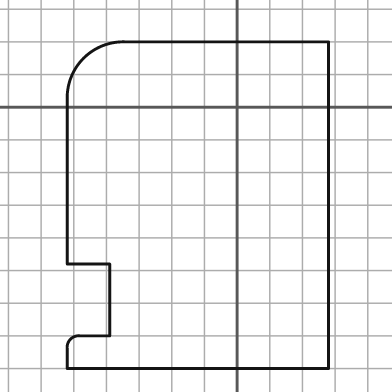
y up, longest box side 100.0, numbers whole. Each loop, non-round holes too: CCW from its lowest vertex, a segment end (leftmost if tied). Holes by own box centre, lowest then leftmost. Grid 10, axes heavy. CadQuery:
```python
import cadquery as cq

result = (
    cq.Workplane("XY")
    .moveTo(-52.0, -80.0)
    .lineTo(28.0, -80.0)
    .lineTo(28.0, 20.0)
    .lineTo(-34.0, 20.0)
    .threePointArc((-47.0, 15.0), (-52.0, 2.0))
    .lineTo(-52.0, -48.0)
    .lineTo(-39.0, -48.0)
    .lineTo(-39.0, -70.0)
    .lineTo(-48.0, -70.0)
    .threePointArc((-51.0, -71.0), (-52.0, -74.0))
    .close()
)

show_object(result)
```